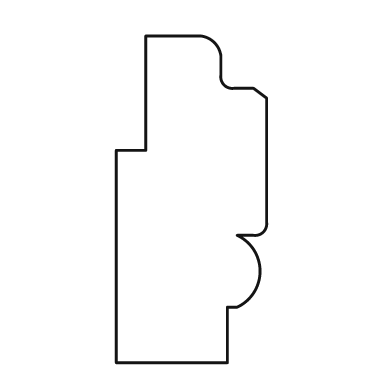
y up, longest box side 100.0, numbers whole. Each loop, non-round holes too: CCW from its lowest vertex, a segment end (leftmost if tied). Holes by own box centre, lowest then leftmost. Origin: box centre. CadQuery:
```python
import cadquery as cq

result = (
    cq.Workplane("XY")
    .moveTo(-23.0, -50.0)
    .lineTo(11.0, -50.0)
    .lineTo(11.0, -33.0)
    .lineTo(14.0, -33.0)
    .threePointArc((21.0, -22.0), (14.0, -11.0))
    .lineTo(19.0, -11.0)
    .threePointArc((22.0, -10.0), (23.0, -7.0))
    .lineTo(23.0, 31.0)
    .lineTo(19.0, 34.0)
    .lineTo(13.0, 34.0)
    .threePointArc((10.0, 35.0), (9.0, 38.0))
    .lineTo(9.0, 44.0)
    .threePointArc((7.0, 48.0), (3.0, 50.0))
    .lineTo(-14.0, 50.0)
    .lineTo(-14.0, 15.0)
    .lineTo(-23.0, 15.0)
    .close()
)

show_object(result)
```